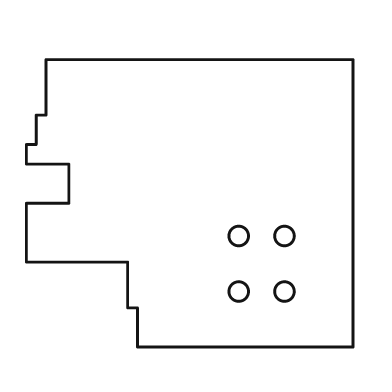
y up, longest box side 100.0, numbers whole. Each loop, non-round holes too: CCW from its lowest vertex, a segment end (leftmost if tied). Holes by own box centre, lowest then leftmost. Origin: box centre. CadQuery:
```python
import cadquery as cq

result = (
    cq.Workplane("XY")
    .moveTo(-16.0, -44.0)
    .lineTo(50.0, -44.0)
    .lineTo(50.0, 44.0)
    .lineTo(-44.0, 44.0)
    .lineTo(-44.0, 27.0)
    .lineTo(-47.0, 27.0)
    .lineTo(-47.0, 18.0)
    .lineTo(-50.0, 18.0)
    .lineTo(-50.0, 12.0)
    .lineTo(-37.0, 12.0)
    .lineTo(-37.0, 0.0)
    .lineTo(-50.0, 0.0)
    .lineTo(-50.0, -18.0)
    .lineTo(-19.0, -18.0)
    .lineTo(-19.0, -32.0)
    .lineTo(-16.0, -32.0)
    .close()
    .moveTo(15.0, -27.0)
    .circle(3.0)
    .moveTo(29.0, -27.0)
    .circle(3.0)
    .moveTo(15.0, -10.0)
    .circle(3.0)
    .moveTo(29.0, -10.0)
    .circle(3.0)
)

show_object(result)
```